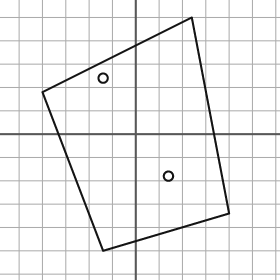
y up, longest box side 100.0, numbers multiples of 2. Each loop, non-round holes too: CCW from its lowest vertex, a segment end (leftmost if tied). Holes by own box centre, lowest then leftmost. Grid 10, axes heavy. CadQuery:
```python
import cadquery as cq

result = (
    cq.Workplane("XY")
    .moveTo(-14.0, -50.0)
    .lineTo(40.0, -34.0)
    .lineTo(24.0, 50.0)
    .lineTo(-40.0, 18.0)
    .close()
    .moveTo(14.0, -18.0)
    .circle(2.0)
    .moveTo(-14.0, 24.0)
    .circle(2.0)
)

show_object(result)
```